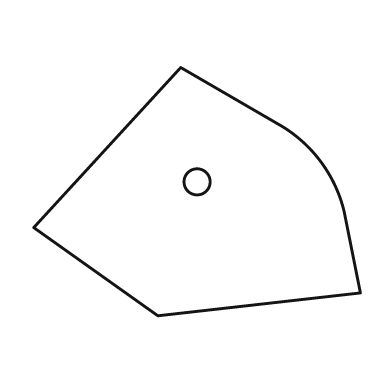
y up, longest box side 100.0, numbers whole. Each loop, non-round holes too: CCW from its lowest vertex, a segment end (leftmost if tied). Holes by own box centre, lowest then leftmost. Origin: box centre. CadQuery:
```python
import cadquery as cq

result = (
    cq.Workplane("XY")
    .moveTo(-12.0, -38.0)
    .lineTo(50.0, -31.0)
    .lineTo(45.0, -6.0)
    .threePointArc((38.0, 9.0), (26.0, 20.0))
    .lineTo(-5.0, 38.0)
    .lineTo(-50.0, -11.0)
    .close()
    .moveTo(0.0, 3.0)
    .circle(4.0)
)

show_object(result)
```